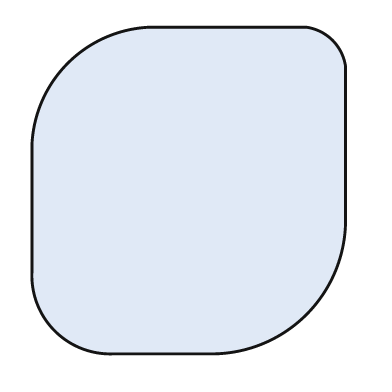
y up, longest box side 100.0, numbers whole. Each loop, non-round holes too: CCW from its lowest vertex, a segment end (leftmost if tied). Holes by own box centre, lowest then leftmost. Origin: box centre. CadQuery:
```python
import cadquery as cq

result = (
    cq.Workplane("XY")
    .moveTo(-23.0, -50.0)
    .lineTo(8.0, -50.0)
    .threePointArc((36.0, -38.0), (48.0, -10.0))
    .lineTo(48.0, 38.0)
    .threePointArc((44.0, 46.0), (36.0, 50.0))
    .lineTo(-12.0, 50.0)
    .threePointArc((-37.0, 39.0), (-48.0, 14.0))
    .lineTo(-48.0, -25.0)
    .threePointArc((-41.0, -43.0), (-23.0, -50.0))
    .close()
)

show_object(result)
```